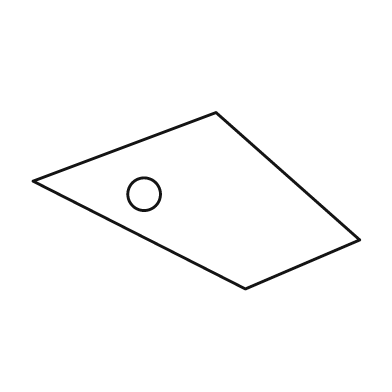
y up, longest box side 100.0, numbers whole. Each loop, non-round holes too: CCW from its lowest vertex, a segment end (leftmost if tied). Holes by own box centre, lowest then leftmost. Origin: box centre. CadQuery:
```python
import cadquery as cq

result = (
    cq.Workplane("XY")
    .moveTo(15.0, -27.0)
    .lineTo(50.0, -12.0)
    .lineTo(6.0, 27.0)
    .lineTo(-50.0, 6.0)
    .close()
    .moveTo(-16.0, 2.0)
    .circle(5.0)
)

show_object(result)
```